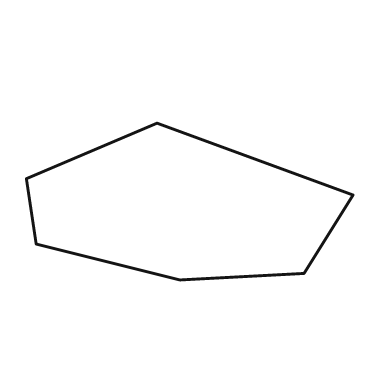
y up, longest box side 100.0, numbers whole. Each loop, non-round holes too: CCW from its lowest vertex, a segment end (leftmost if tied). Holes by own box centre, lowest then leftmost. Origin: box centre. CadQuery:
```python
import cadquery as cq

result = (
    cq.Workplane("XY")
    .moveTo(-3.0, -24.0)
    .lineTo(35.0, -22.0)
    .lineTo(50.0, 2.0)
    .lineTo(-10.0, 24.0)
    .lineTo(-50.0, 7.0)
    .lineTo(-47.0, -13.0)
    .close()
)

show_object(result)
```